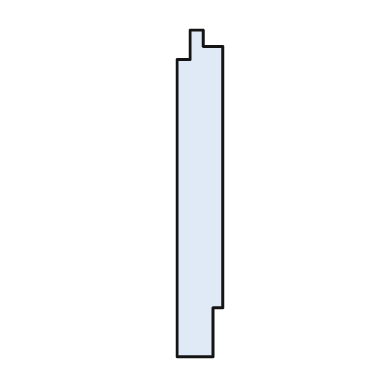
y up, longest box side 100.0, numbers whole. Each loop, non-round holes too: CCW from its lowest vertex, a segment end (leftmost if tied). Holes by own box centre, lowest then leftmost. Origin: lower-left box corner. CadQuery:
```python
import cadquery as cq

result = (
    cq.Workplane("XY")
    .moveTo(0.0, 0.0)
    .lineTo(11.0, 0.0)
    .lineTo(11.0, 15.0)
    .lineTo(14.0, 15.0)
    .lineTo(14.0, 95.0)
    .lineTo(8.0, 95.0)
    .lineTo(8.0, 100.0)
    .lineTo(4.0, 100.0)
    .lineTo(4.0, 91.0)
    .lineTo(0.0, 91.0)
    .close()
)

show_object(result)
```